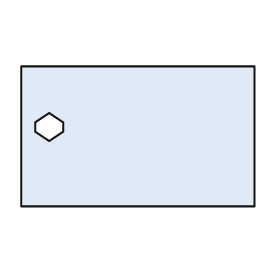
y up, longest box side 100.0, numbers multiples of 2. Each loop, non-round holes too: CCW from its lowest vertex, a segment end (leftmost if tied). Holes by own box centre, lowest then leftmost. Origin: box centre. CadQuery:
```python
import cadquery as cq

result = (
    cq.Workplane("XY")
    .moveTo(-50.0, -30.0)
    .lineTo(50.0, -30.0)
    .lineTo(50.0, 30.0)
    .lineTo(-50.0, 30.0)
    .close()
    .moveTo(-38.0, -2.0)
    .lineTo(-32.0, 2.0)
    .lineTo(-32.0, 6.0)
    .lineTo(-38.0, 10.0)
    .lineTo(-44.0, 6.0)
    .lineTo(-44.0, 2.0)
    .close()
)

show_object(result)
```